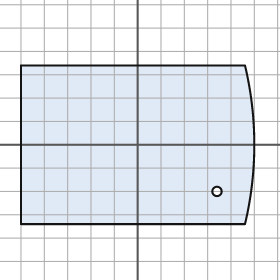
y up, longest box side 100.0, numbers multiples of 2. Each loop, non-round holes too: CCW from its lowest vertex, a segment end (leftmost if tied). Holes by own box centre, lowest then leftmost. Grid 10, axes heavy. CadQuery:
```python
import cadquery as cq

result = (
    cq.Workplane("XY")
    .moveTo(-50.0, -34.0)
    .lineTo(46.0, -34.0)
    .threePointArc((50.0, 0.0), (46.0, 34.0))
    .lineTo(-50.0, 34.0)
    .close()
    .moveTo(34.0, -20.0)
    .circle(2.0)
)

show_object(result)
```